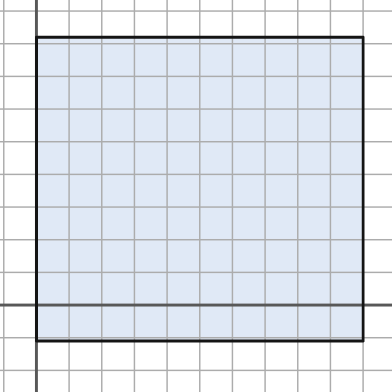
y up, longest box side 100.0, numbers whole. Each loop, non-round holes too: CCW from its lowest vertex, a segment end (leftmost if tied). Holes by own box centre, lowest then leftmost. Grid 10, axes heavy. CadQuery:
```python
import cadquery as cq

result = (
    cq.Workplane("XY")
    .moveTo(0.0, -11.0)
    .lineTo(100.0, -11.0)
    .lineTo(100.0, 82.0)
    .lineTo(0.0, 82.0)
    .close()
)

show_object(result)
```